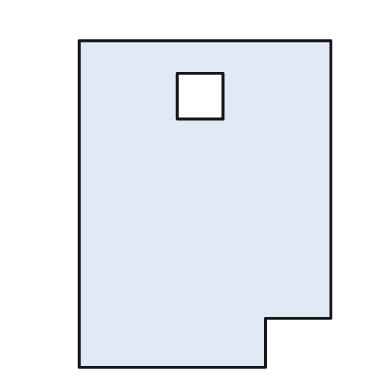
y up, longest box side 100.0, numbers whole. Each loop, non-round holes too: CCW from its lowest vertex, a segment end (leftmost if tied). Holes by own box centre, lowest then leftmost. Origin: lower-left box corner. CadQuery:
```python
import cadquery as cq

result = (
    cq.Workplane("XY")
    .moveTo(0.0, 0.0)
    .lineTo(57.0, 0.0)
    .lineTo(57.0, 15.0)
    .lineTo(77.0, 15.0)
    .lineTo(77.0, 100.0)
    .lineTo(0.0, 100.0)
    .close()
    .moveTo(30.0, 76.0)
    .lineTo(44.0, 76.0)
    .lineTo(44.0, 90.0)
    .lineTo(30.0, 90.0)
    .close()
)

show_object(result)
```